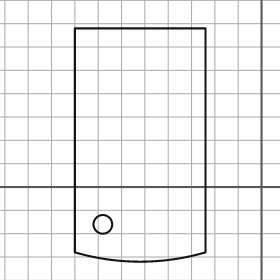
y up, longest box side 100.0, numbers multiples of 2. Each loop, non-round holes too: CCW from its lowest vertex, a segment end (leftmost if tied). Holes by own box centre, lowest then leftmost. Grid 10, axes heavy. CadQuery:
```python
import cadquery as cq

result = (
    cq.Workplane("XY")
    .moveTo(-80.0, -28.0)
    .threePointArc((-52.0, -32.0), (-24.0, -28.0))
    .lineTo(-24.0, 68.0)
    .lineTo(-80.0, 68.0)
    .close()
    .moveTo(-68.0, -16.0)
    .circle(4.0)
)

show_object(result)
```